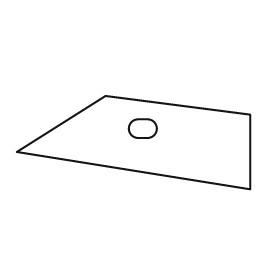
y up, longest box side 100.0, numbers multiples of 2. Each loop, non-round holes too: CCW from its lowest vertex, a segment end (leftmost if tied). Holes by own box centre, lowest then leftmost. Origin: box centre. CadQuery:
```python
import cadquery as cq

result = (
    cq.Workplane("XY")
    .moveTo(50.0, -20.0)
    .lineTo(50.0, 12.0)
    .lineTo(-12.0, 20.0)
    .lineTo(-50.0, -4.0)
    .close()
    .moveTo(2.0, 2.0)
    .lineTo(6.0, 2.0)
    .threePointArc((10.0, 6.0), (6.0, 10.0))
    .lineTo(2.0, 10.0)
    .threePointArc((-2.0, 6.0), (2.0, 2.0))
    .close()
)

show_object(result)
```